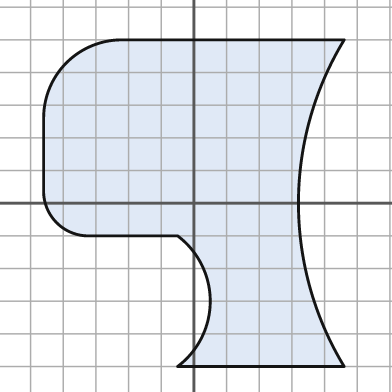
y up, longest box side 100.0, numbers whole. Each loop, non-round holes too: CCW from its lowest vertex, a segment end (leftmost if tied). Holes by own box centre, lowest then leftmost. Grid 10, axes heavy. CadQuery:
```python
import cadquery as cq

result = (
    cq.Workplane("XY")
    .moveTo(-5.0, -50.0)
    .lineTo(46.0, -50.0)
    .threePointArc((32.0, 0.0), (46.0, 50.0))
    .lineTo(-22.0, 50.0)
    .threePointArc((-39.0, 43.0), (-46.0, 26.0))
    .lineTo(-46.0, 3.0)
    .threePointArc((-42.0, -6.0), (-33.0, -10.0))
    .lineTo(-5.0, -10.0)
    .threePointArc((5.0, -30.0), (-5.0, -50.0))
    .close()
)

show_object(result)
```